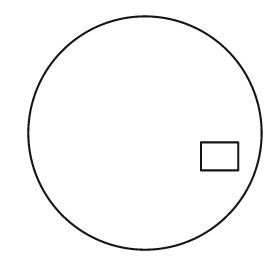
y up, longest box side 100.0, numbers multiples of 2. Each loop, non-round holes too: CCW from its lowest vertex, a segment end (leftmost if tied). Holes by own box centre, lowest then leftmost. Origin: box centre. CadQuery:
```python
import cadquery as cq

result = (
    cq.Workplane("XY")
    .moveTo(0.0, 0.0)
    .circle(50.0)
    .moveTo(24.0, -16.0)
    .lineTo(40.0, -16.0)
    .lineTo(40.0, -4.0)
    .lineTo(24.0, -4.0)
    .close()
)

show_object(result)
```